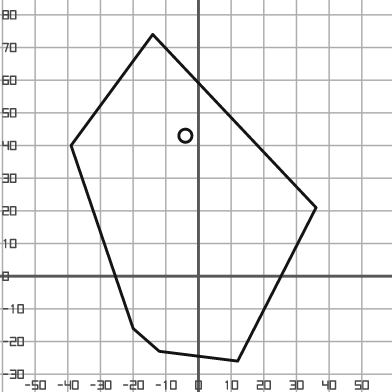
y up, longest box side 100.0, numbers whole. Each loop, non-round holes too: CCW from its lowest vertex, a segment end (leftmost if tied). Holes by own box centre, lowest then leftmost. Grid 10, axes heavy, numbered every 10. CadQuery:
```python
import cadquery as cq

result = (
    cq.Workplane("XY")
    .moveTo(12.0, -26.0)
    .lineTo(36.0, 21.0)
    .lineTo(-14.0, 74.0)
    .lineTo(-39.0, 40.0)
    .lineTo(-20.0, -16.0)
    .lineTo(-12.0, -23.0)
    .close()
    .moveTo(-4.0, 43.0)
    .circle(2.0)
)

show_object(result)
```